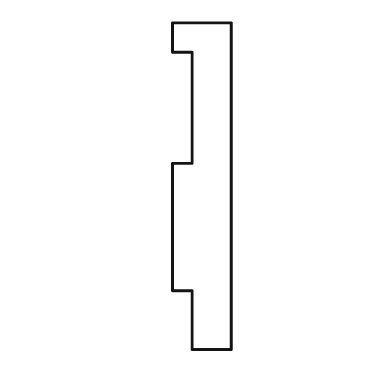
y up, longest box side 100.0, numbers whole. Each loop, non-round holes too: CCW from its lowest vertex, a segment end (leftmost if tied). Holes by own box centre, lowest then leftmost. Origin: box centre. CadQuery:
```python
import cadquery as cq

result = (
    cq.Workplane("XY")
    .moveTo(-3.0, -50.0)
    .lineTo(9.0, -50.0)
    .lineTo(9.0, 50.0)
    .lineTo(-9.0, 50.0)
    .lineTo(-9.0, 41.0)
    .lineTo(-3.0, 41.0)
    .lineTo(-3.0, 7.0)
    .lineTo(-9.0, 7.0)
    .lineTo(-9.0, -32.0)
    .lineTo(-3.0, -32.0)
    .close()
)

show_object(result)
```